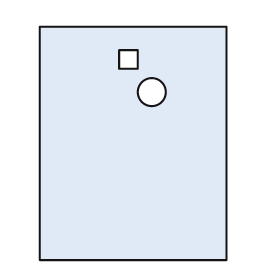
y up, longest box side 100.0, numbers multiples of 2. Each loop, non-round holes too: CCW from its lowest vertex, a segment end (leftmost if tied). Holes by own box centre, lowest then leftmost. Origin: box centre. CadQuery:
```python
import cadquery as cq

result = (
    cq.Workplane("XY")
    .moveTo(-40.0, -50.0)
    .lineTo(40.0, -50.0)
    .lineTo(40.0, 50.0)
    .lineTo(-40.0, 50.0)
    .close()
    .moveTo(8.0, 22.0)
    .circle(6.0)
    .moveTo(-6.0, 32.0)
    .lineTo(2.0, 32.0)
    .lineTo(2.0, 40.0)
    .lineTo(-6.0, 40.0)
    .close()
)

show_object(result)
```